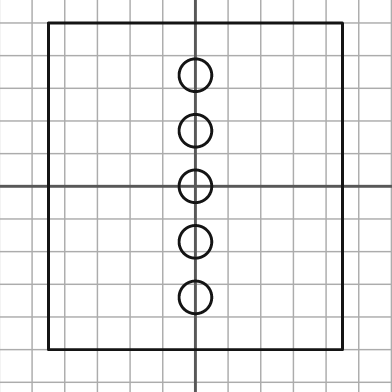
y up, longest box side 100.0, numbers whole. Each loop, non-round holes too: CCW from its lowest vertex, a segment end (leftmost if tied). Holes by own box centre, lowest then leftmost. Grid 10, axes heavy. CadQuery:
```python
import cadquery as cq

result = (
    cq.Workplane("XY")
    .moveTo(-45.0, -50.0)
    .lineTo(45.0, -50.0)
    .lineTo(45.0, 50.0)
    .lineTo(-45.0, 50.0)
    .close()
    .moveTo(0.0, -34.0)
    .circle(5.0)
    .moveTo(0.0, -17.0)
    .circle(5.0)
    .moveTo(0.0, 0.0)
    .circle(5.0)
    .moveTo(0.0, 17.0)
    .circle(5.0)
    .moveTo(0.0, 34.0)
    .circle(5.0)
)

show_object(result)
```